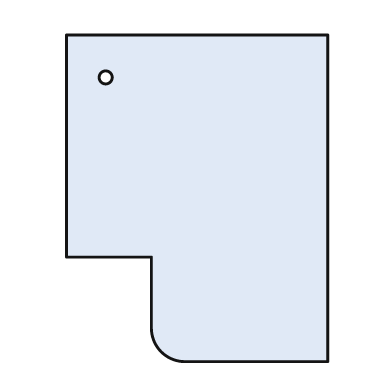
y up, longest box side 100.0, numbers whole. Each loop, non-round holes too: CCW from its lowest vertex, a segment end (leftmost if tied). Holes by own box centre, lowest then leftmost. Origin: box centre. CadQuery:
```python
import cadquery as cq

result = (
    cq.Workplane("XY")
    .moveTo(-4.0, -50.0)
    .lineTo(40.0, -50.0)
    .lineTo(40.0, 50.0)
    .lineTo(-40.0, 50.0)
    .lineTo(-40.0, -18.0)
    .lineTo(-14.0, -18.0)
    .lineTo(-14.0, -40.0)
    .threePointArc((-11.0, -47.0), (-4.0, -50.0))
    .close()
    .moveTo(-28.0, 37.0)
    .circle(2.0)
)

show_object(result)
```